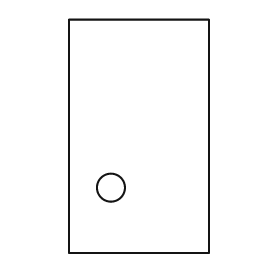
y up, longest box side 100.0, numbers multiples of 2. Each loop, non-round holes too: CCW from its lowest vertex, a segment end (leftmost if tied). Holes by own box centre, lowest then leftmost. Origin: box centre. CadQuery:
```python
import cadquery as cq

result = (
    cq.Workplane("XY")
    .moveTo(-30.0, -50.0)
    .lineTo(30.0, -50.0)
    .lineTo(30.0, 50.0)
    .lineTo(-30.0, 50.0)
    .close()
    .moveTo(-12.0, -22.0)
    .circle(6.0)
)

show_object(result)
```